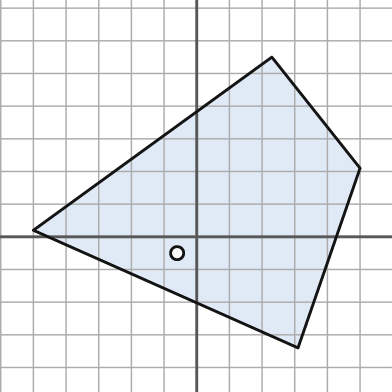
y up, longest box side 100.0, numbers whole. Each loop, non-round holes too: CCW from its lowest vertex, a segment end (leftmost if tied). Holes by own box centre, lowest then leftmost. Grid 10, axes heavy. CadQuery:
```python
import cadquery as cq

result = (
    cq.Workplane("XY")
    .moveTo(31.0, -34.0)
    .lineTo(50.0, 21.0)
    .lineTo(23.0, 55.0)
    .lineTo(-50.0, 2.0)
    .close()
    .moveTo(-6.0, -5.0)
    .circle(2.0)
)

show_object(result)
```